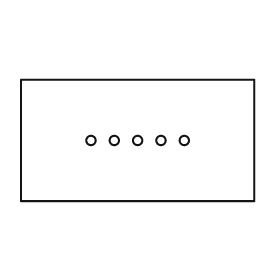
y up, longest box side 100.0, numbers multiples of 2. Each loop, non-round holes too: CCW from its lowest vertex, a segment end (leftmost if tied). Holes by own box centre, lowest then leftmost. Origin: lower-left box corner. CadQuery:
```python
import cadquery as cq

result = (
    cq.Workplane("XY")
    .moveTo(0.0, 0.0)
    .lineTo(100.0, 0.0)
    .lineTo(100.0, 52.0)
    .lineTo(0.0, 52.0)
    .close()
    .moveTo(30.0, 26.0)
    .circle(2.0)
    .moveTo(40.0, 26.0)
    .circle(2.0)
    .moveTo(50.0, 26.0)
    .circle(2.0)
    .moveTo(60.0, 26.0)
    .circle(2.0)
    .moveTo(70.0, 26.0)
    .circle(2.0)
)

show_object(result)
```